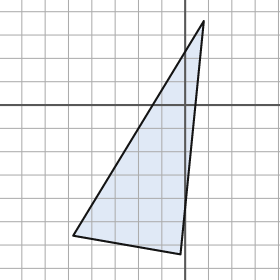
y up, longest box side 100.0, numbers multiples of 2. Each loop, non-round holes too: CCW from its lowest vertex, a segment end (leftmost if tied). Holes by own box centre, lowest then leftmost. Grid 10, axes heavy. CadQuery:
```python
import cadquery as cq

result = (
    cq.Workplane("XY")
    .moveTo(-2.0, -64.0)
    .lineTo(8.0, 36.0)
    .lineTo(-48.0, -56.0)
    .close()
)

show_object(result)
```